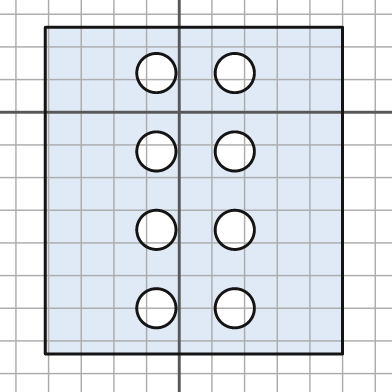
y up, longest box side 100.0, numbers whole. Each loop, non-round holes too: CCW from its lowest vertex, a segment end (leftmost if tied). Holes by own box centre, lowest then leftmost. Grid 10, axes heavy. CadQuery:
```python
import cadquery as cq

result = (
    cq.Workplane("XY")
    .moveTo(-41.0, -74.0)
    .lineTo(50.0, -74.0)
    .lineTo(50.0, 26.0)
    .lineTo(-41.0, 26.0)
    .close()
    .moveTo(-7.0, -60.0)
    .circle(6.0)
    .moveTo(17.0, -60.0)
    .circle(6.0)
    .moveTo(-7.0, -36.0)
    .circle(6.0)
    .moveTo(17.0, -36.0)
    .circle(6.0)
    .moveTo(-7.0, -12.0)
    .circle(6.0)
    .moveTo(17.0, -12.0)
    .circle(6.0)
    .moveTo(-7.0, 12.0)
    .circle(6.0)
    .moveTo(17.0, 12.0)
    .circle(6.0)
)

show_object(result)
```